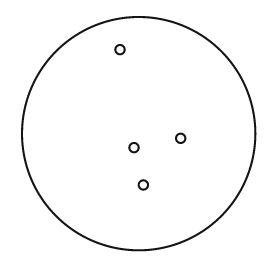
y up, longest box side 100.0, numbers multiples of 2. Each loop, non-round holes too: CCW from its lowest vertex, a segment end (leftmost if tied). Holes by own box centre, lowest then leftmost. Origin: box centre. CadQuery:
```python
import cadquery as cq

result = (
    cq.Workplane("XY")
    .moveTo(0.0, 0.0)
    .circle(50.0)
    .moveTo(2.0, -22.0)
    .circle(2.0)
    .moveTo(-2.0, -6.0)
    .circle(2.0)
    .moveTo(18.0, -2.0)
    .circle(2.0)
    .moveTo(-8.0, 36.0)
    .circle(2.0)
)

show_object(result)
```